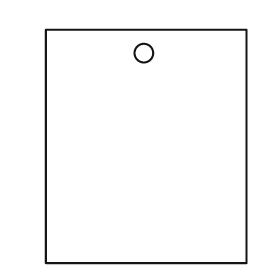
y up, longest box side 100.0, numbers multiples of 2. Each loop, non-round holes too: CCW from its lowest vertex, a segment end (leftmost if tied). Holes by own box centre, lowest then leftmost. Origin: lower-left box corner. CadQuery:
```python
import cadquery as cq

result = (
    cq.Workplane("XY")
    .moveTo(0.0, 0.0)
    .lineTo(86.0, 0.0)
    .lineTo(86.0, 100.0)
    .lineTo(0.0, 100.0)
    .close()
    .moveTo(42.0, 90.0)
    .circle(4.0)
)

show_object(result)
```